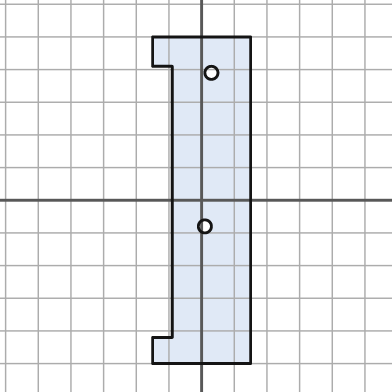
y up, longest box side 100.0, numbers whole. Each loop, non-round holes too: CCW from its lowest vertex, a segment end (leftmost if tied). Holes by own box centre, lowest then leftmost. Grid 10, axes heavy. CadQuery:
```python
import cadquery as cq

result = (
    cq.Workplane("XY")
    .moveTo(-15.0, -50.0)
    .lineTo(15.0, -50.0)
    .lineTo(15.0, 50.0)
    .lineTo(-15.0, 50.0)
    .lineTo(-15.0, 41.0)
    .lineTo(-9.0, 41.0)
    .lineTo(-9.0, -42.0)
    .lineTo(-15.0, -42.0)
    .close()
    .moveTo(1.0, -8.0)
    .circle(2.0)
    .moveTo(3.0, 39.0)
    .circle(2.0)
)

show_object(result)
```